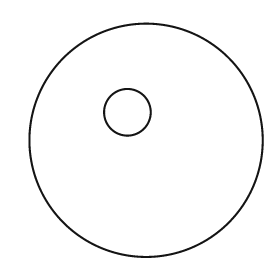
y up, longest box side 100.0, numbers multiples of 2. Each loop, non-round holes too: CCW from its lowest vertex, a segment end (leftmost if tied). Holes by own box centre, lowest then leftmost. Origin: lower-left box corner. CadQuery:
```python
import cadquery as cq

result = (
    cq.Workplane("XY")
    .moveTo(50.0, 50.0)
    .circle(50.0)
    .moveTo(42.0, 62.0)
    .circle(10.0)
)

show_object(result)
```